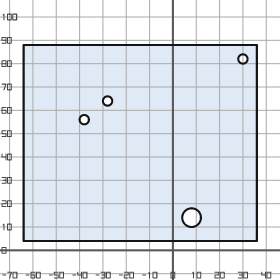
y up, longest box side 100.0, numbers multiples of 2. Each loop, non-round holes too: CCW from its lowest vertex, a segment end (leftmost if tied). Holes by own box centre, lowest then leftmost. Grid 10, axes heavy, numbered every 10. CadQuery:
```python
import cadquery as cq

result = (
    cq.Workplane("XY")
    .moveTo(-64.0, 4.0)
    .lineTo(36.0, 4.0)
    .lineTo(36.0, 88.0)
    .lineTo(-64.0, 88.0)
    .close()
    .moveTo(8.0, 14.0)
    .circle(4.0)
    .moveTo(-38.0, 56.0)
    .circle(2.0)
    .moveTo(-28.0, 64.0)
    .circle(2.0)
    .moveTo(30.0, 82.0)
    .circle(2.0)
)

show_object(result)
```